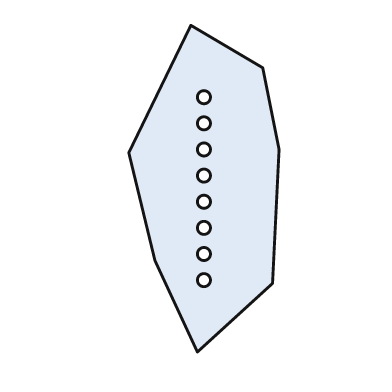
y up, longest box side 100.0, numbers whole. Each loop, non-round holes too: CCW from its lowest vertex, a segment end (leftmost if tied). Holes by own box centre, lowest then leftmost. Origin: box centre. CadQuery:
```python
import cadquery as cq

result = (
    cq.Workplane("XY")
    .moveTo(-2.0, -50.0)
    .lineTo(21.0, -29.0)
    .lineTo(23.0, 12.0)
    .lineTo(18.0, 37.0)
    .lineTo(-4.0, 50.0)
    .lineTo(-23.0, 11.0)
    .lineTo(-15.0, -22.0)
    .close()
    .moveTo(0.0, -28.0)
    .circle(2.0)
    .moveTo(0.0, -20.0)
    .circle(2.0)
    .moveTo(0.0, -12.0)
    .circle(2.0)
    .moveTo(0.0, -4.0)
    .circle(2.0)
    .moveTo(0.0, 4.0)
    .circle(2.0)
    .moveTo(0.0, 12.0)
    .circle(2.0)
    .moveTo(0.0, 20.0)
    .circle(2.0)
    .moveTo(0.0, 28.0)
    .circle(2.0)
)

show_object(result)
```